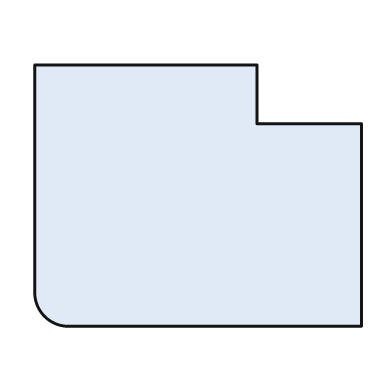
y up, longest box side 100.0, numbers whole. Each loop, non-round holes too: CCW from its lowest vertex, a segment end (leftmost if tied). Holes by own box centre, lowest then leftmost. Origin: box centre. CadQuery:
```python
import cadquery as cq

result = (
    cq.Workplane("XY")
    .moveTo(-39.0, -40.0)
    .lineTo(50.0, -40.0)
    .lineTo(50.0, 22.0)
    .lineTo(18.0, 22.0)
    .lineTo(18.0, 40.0)
    .lineTo(-50.0, 40.0)
    .lineTo(-50.0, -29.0)
    .threePointArc((-47.0, -37.0), (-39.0, -40.0))
    .close()
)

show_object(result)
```